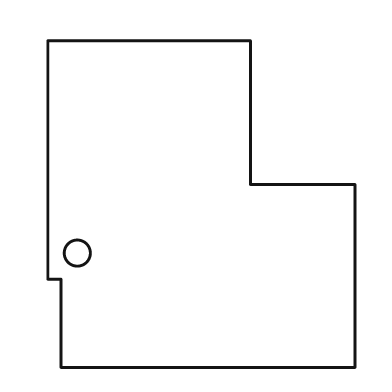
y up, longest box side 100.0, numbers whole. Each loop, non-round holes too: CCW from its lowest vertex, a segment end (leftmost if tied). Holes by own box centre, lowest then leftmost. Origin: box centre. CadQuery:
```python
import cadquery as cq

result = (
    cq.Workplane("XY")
    .moveTo(-43.0, -50.0)
    .lineTo(47.0, -50.0)
    .lineTo(47.0, 6.0)
    .lineTo(15.0, 6.0)
    .lineTo(15.0, 50.0)
    .lineTo(-47.0, 50.0)
    .lineTo(-47.0, -23.0)
    .lineTo(-43.0, -23.0)
    .close()
    .moveTo(-38.0, -15.0)
    .circle(4.0)
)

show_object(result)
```